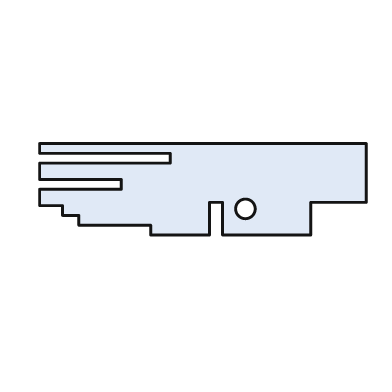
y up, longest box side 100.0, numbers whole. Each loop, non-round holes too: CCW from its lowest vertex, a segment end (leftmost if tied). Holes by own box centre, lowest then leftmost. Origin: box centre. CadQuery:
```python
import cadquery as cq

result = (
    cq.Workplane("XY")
    .moveTo(-16.0, -14.0)
    .lineTo(2.0, -14.0)
    .lineTo(2.0, -4.0)
    .lineTo(6.0, -4.0)
    .lineTo(6.0, -14.0)
    .lineTo(33.0, -14.0)
    .lineTo(33.0, -4.0)
    .lineTo(50.0, -4.0)
    .lineTo(50.0, 14.0)
    .lineTo(-50.0, 14.0)
    .lineTo(-50.0, 11.0)
    .lineTo(-10.0, 11.0)
    .lineTo(-10.0, 8.0)
    .lineTo(-50.0, 8.0)
    .lineTo(-50.0, 3.0)
    .lineTo(-25.0, 3.0)
    .lineTo(-25.0, 0.0)
    .lineTo(-50.0, 0.0)
    .lineTo(-50.0, -5.0)
    .lineTo(-43.0, -5.0)
    .lineTo(-43.0, -8.0)
    .lineTo(-38.0, -8.0)
    .lineTo(-38.0, -11.0)
    .lineTo(-16.0, -11.0)
    .close()
    .moveTo(13.0, -6.0)
    .circle(3.0)
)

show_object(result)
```